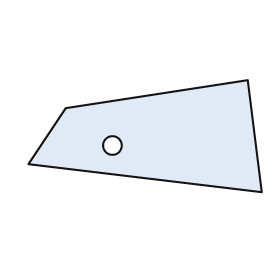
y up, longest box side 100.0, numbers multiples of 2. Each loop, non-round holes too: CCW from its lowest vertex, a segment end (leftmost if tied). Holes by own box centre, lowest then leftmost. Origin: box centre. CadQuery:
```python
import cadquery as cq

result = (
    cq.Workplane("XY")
    .moveTo(50.0, -24.0)
    .lineTo(44.0, 24.0)
    .lineTo(-34.0, 12.0)
    .lineTo(-50.0, -12.0)
    .close()
    .moveTo(-14.0, -4.0)
    .circle(4.0)
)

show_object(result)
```